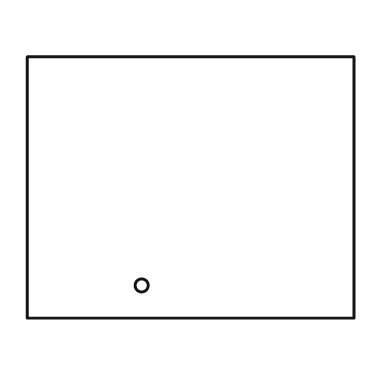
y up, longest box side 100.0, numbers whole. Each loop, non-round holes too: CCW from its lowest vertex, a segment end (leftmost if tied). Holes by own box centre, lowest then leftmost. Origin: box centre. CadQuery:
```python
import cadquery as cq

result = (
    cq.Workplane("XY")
    .moveTo(-50.0, -40.0)
    .lineTo(50.0, -40.0)
    .lineTo(50.0, 40.0)
    .lineTo(-50.0, 40.0)
    .close()
    .moveTo(-15.0, -30.0)
    .circle(2.0)
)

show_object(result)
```